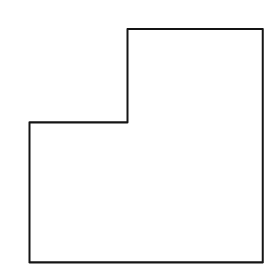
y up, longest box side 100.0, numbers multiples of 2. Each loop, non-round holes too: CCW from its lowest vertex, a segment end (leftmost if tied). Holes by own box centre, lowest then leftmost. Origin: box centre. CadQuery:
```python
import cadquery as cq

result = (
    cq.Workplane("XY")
    .moveTo(-50.0, -50.0)
    .lineTo(50.0, -50.0)
    .lineTo(50.0, 50.0)
    .lineTo(-8.0, 50.0)
    .lineTo(-8.0, 10.0)
    .lineTo(-50.0, 10.0)
    .close()
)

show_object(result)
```